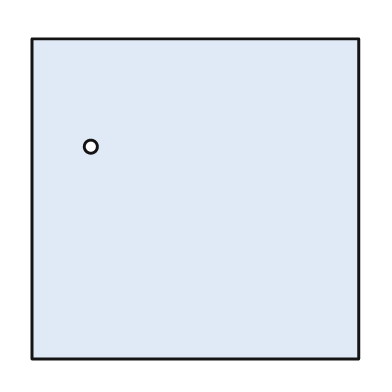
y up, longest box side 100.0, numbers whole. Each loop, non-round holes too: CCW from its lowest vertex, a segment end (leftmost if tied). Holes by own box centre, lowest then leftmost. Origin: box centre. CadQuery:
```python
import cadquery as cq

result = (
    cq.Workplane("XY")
    .moveTo(-50.0, -49.0)
    .lineTo(50.0, -49.0)
    .lineTo(50.0, 49.0)
    .lineTo(-50.0, 49.0)
    .close()
    .moveTo(-32.0, 16.0)
    .circle(2.0)
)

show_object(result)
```